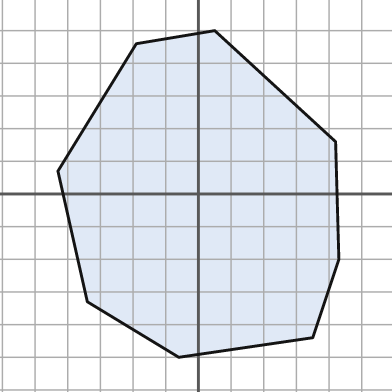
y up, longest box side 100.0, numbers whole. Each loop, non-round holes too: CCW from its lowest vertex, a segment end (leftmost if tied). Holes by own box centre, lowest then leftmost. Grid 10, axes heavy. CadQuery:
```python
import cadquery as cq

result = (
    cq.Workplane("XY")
    .moveTo(-6.0, -50.0)
    .lineTo(35.0, -44.0)
    .lineTo(43.0, -20.0)
    .lineTo(42.0, 16.0)
    .lineTo(5.0, 50.0)
    .lineTo(-19.0, 46.0)
    .lineTo(-43.0, 7.0)
    .lineTo(-34.0, -33.0)
    .close()
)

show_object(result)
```